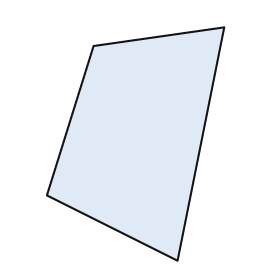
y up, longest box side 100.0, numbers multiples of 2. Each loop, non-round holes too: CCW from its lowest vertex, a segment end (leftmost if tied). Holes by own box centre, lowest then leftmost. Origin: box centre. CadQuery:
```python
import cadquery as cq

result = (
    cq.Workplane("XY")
    .moveTo(18.0, -50.0)
    .lineTo(38.0, 50.0)
    .lineTo(-18.0, 42.0)
    .lineTo(-38.0, -22.0)
    .close()
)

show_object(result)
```